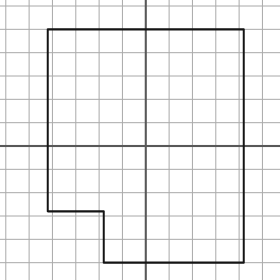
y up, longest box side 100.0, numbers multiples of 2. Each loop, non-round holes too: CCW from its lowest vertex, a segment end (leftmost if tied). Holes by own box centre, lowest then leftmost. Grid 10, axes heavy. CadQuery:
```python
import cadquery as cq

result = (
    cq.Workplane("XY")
    .moveTo(-18.0, -50.0)
    .lineTo(42.0, -50.0)
    .lineTo(42.0, 50.0)
    .lineTo(-42.0, 50.0)
    .lineTo(-42.0, -28.0)
    .lineTo(-18.0, -28.0)
    .close()
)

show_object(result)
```